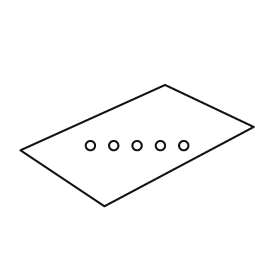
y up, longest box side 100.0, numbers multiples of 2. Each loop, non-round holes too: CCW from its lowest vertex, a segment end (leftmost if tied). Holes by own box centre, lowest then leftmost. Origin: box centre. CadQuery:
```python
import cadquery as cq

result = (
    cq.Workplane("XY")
    .moveTo(-14.0, -26.0)
    .lineTo(50.0, 8.0)
    .lineTo(12.0, 26.0)
    .lineTo(-50.0, -2.0)
    .close()
    .moveTo(-20.0, 0.0)
    .circle(2.0)
    .moveTo(-10.0, 0.0)
    .circle(2.0)
    .moveTo(0.0, 0.0)
    .circle(2.0)
    .moveTo(10.0, 0.0)
    .circle(2.0)
    .moveTo(20.0, 0.0)
    .circle(2.0)
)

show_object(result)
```